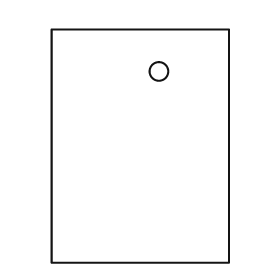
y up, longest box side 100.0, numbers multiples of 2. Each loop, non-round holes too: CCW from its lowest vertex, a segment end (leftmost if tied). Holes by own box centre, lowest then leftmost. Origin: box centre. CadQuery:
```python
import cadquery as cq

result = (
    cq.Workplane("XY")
    .moveTo(-38.0, -50.0)
    .lineTo(38.0, -50.0)
    .lineTo(38.0, 50.0)
    .lineTo(-38.0, 50.0)
    .close()
    .moveTo(8.0, 32.0)
    .circle(4.0)
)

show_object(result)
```